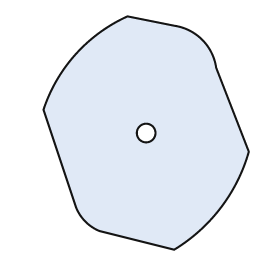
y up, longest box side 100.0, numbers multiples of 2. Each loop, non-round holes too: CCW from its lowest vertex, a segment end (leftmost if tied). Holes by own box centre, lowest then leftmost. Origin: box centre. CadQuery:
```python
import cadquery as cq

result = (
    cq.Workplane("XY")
    .moveTo(12.0, -50.0)
    .threePointArc((32.0, -32.0), (44.0, -8.0))
    .lineTo(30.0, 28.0)
    .threePointArc((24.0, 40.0), (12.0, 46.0))
    .lineTo(-8.0, 50.0)
    .threePointArc((-30.0, 34.0), (-44.0, 10.0))
    .lineTo(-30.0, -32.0)
    .threePointArc((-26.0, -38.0), (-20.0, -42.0))
    .close()
    .moveTo(0.0, 0.0)
    .circle(4.0)
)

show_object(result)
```